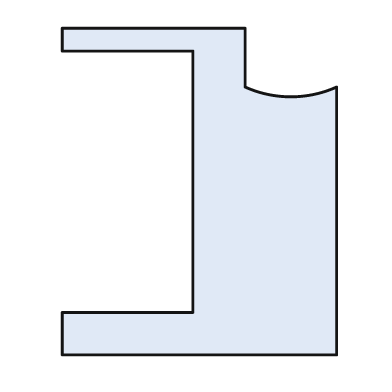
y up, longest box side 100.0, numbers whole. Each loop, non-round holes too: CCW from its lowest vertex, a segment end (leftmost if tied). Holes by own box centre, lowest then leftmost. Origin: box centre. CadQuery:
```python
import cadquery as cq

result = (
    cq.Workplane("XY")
    .moveTo(-42.0, -50.0)
    .lineTo(42.0, -50.0)
    .lineTo(42.0, 32.0)
    .threePointArc((28.0, 29.0), (14.0, 32.0))
    .lineTo(14.0, 50.0)
    .lineTo(-42.0, 50.0)
    .lineTo(-42.0, 43.0)
    .lineTo(-2.0, 43.0)
    .lineTo(-2.0, -37.0)
    .lineTo(-42.0, -37.0)
    .close()
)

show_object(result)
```